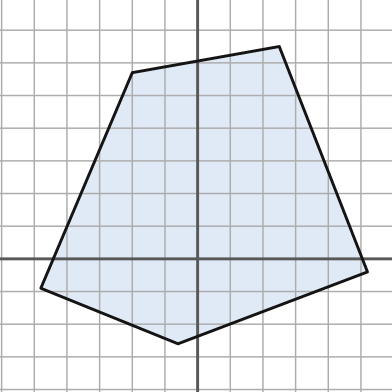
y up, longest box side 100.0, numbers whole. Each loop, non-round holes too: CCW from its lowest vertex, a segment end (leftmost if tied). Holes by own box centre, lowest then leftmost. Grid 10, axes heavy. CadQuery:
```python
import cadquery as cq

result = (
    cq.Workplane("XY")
    .moveTo(-6.0, -26.0)
    .lineTo(52.0, -4.0)
    .lineTo(25.0, 65.0)
    .lineTo(-20.0, 57.0)
    .lineTo(-48.0, -9.0)
    .close()
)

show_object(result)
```